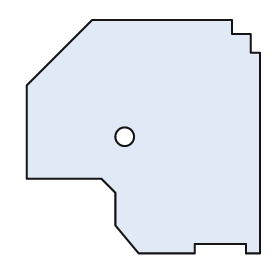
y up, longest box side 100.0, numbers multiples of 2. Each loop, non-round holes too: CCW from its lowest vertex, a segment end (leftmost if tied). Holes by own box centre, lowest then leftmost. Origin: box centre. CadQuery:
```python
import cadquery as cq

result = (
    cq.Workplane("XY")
    .moveTo(-2.0, -50.0)
    .lineTo(22.0, -50.0)
    .lineTo(22.0, -46.0)
    .lineTo(44.0, -46.0)
    .lineTo(44.0, -50.0)
    .lineTo(50.0, -50.0)
    .lineTo(50.0, 36.0)
    .lineTo(46.0, 36.0)
    .lineTo(46.0, 44.0)
    .lineTo(38.0, 44.0)
    .lineTo(38.0, 50.0)
    .lineTo(-22.0, 50.0)
    .lineTo(-50.0, 22.0)
    .lineTo(-50.0, -18.0)
    .lineTo(-18.0, -18.0)
    .lineTo(-12.0, -24.0)
    .lineTo(-12.0, -38.0)
    .close()
    .moveTo(-8.0, 0.0)
    .circle(4.0)
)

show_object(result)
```